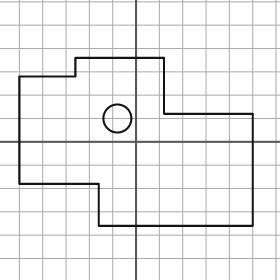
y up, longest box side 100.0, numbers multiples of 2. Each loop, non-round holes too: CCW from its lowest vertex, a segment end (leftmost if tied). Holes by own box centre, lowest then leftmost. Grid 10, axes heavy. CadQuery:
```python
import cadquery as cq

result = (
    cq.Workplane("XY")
    .moveTo(-16.0, -36.0)
    .lineTo(50.0, -36.0)
    .lineTo(50.0, 12.0)
    .lineTo(12.0, 12.0)
    .lineTo(12.0, 36.0)
    .lineTo(-26.0, 36.0)
    .lineTo(-26.0, 28.0)
    .lineTo(-50.0, 28.0)
    .lineTo(-50.0, -18.0)
    .lineTo(-16.0, -18.0)
    .close()
    .moveTo(-8.0, 10.0)
    .circle(6.0)
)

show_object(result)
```